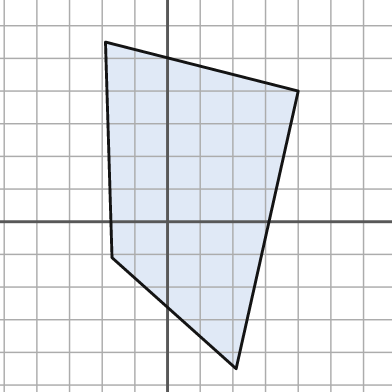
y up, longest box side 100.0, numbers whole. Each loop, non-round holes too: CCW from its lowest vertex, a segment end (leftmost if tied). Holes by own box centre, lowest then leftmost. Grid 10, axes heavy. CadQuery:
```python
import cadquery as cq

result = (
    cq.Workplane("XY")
    .moveTo(21.0, -45.0)
    .lineTo(40.0, 40.0)
    .lineTo(-19.0, 55.0)
    .lineTo(-17.0, -11.0)
    .close()
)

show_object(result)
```